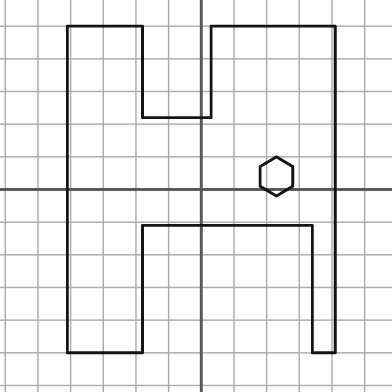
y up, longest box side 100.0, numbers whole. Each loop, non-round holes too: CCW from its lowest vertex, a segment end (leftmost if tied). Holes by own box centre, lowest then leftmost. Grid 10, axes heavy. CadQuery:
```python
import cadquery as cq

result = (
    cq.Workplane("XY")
    .moveTo(-41.0, -50.0)
    .lineTo(-18.0, -50.0)
    .lineTo(-18.0, -11.0)
    .lineTo(34.0, -11.0)
    .lineTo(34.0, -50.0)
    .lineTo(41.0, -50.0)
    .lineTo(41.0, 50.0)
    .lineTo(3.0, 50.0)
    .lineTo(3.0, 22.0)
    .lineTo(-18.0, 22.0)
    .lineTo(-18.0, 50.0)
    .lineTo(-41.0, 50.0)
    .close()
    .moveTo(23.0, -2.0)
    .lineTo(28.0, 1.0)
    .lineTo(28.0, 7.0)
    .lineTo(23.0, 10.0)
    .lineTo(18.0, 7.0)
    .lineTo(18.0, 1.0)
    .close()
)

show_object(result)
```